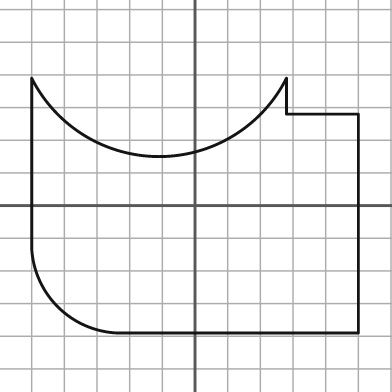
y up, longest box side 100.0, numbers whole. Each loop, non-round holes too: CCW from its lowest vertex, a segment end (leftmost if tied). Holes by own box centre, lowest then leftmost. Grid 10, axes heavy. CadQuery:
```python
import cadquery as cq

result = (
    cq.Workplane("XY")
    .moveTo(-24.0, -39.0)
    .lineTo(50.0, -39.0)
    .lineTo(50.0, 28.0)
    .lineTo(28.0, 28.0)
    .lineTo(28.0, 39.0)
    .threePointArc((-11.0, 15.0), (-50.0, 39.0))
    .lineTo(-50.0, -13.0)
    .threePointArc((-42.0, -31.0), (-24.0, -39.0))
    .close()
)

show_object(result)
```